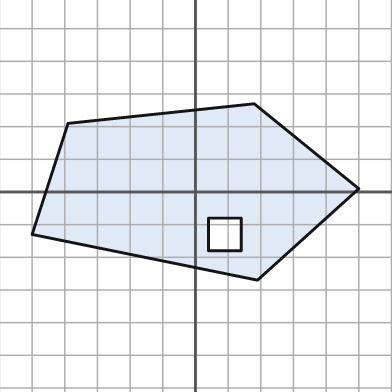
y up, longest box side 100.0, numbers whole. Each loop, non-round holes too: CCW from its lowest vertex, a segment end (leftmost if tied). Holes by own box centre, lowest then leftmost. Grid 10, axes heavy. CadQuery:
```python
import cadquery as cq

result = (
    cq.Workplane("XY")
    .moveTo(19.0, -27.0)
    .lineTo(50.0, 1.0)
    .lineTo(18.0, 27.0)
    .lineTo(-39.0, 21.0)
    .lineTo(-50.0, -13.0)
    .close()
    .moveTo(4.0, -18.0)
    .lineTo(14.0, -18.0)
    .lineTo(14.0, -8.0)
    .lineTo(4.0, -8.0)
    .close()
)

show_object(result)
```